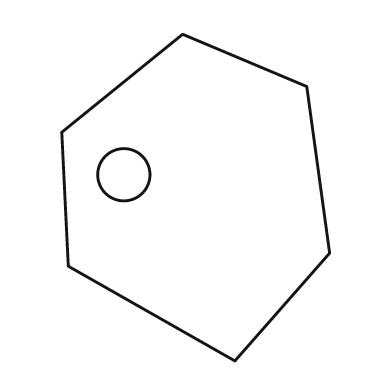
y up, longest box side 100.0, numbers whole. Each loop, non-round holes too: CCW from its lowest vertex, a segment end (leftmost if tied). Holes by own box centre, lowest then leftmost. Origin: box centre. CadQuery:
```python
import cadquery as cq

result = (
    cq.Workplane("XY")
    .moveTo(12.0, -50.0)
    .lineTo(41.0, -17.0)
    .lineTo(34.0, 34.0)
    .lineTo(-4.0, 50.0)
    .lineTo(-41.0, 20.0)
    .lineTo(-39.0, -21.0)
    .close()
    .moveTo(-22.0, 7.0)
    .circle(8.0)
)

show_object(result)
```